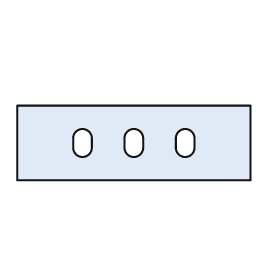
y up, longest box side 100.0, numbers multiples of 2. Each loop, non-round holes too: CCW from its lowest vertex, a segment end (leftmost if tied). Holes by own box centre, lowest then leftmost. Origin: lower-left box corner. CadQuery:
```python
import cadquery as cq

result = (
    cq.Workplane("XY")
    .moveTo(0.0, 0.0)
    .lineTo(100.0, 0.0)
    .lineTo(100.0, 32.0)
    .lineTo(0.0, 32.0)
    .close()
    .moveTo(24.0, 14.0)
    .threePointArc((28.0, 10.0), (32.0, 14.0))
    .lineTo(32.0, 18.0)
    .threePointArc((28.0, 22.0), (24.0, 18.0))
    .close()
    .moveTo(46.0, 14.0)
    .threePointArc((50.0, 10.0), (54.0, 14.0))
    .lineTo(54.0, 18.0)
    .threePointArc((50.0, 22.0), (46.0, 18.0))
    .close()
    .moveTo(68.0, 14.0)
    .threePointArc((72.0, 10.0), (76.0, 14.0))
    .lineTo(76.0, 18.0)
    .threePointArc((72.0, 22.0), (68.0, 18.0))
    .close()
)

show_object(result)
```